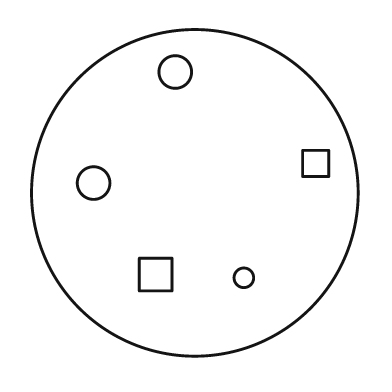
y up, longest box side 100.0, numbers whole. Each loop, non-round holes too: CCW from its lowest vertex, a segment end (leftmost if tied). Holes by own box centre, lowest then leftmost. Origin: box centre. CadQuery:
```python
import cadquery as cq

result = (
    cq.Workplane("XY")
    .moveTo(0.0, 0.0)
    .circle(50.0)
    .moveTo(15.0, -26.0)
    .circle(3.0)
    .moveTo(-17.0, -30.0)
    .lineTo(-7.0, -30.0)
    .lineTo(-7.0, -20.0)
    .lineTo(-17.0, -20.0)
    .close()
    .moveTo(-31.0, 3.0)
    .circle(5.0)
    .moveTo(33.0, 5.0)
    .lineTo(41.0, 5.0)
    .lineTo(41.0, 13.0)
    .lineTo(33.0, 13.0)
    .close()
    .moveTo(-6.0, 37.0)
    .circle(5.0)
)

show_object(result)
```